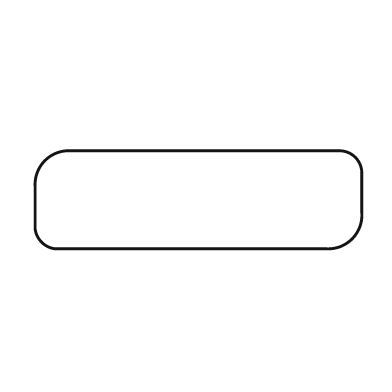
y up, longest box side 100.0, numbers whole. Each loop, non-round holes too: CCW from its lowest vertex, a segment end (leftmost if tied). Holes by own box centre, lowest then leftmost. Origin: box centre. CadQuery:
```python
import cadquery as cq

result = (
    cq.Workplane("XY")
    .moveTo(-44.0, -15.0)
    .lineTo(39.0, -15.0)
    .threePointArc((47.0, -12.0), (50.0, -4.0))
    .lineTo(50.0, 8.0)
    .threePointArc((48.0, 13.0), (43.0, 15.0))
    .lineTo(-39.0, 15.0)
    .threePointArc((-47.0, 12.0), (-50.0, 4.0))
    .lineTo(-50.0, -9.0)
    .threePointArc((-48.0, -13.0), (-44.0, -15.0))
    .close()
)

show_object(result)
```